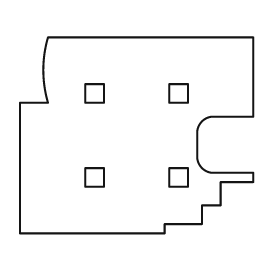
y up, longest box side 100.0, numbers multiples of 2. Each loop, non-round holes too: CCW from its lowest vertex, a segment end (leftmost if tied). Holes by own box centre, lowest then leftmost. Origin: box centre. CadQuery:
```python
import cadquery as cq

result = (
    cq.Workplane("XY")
    .moveTo(-50.0, -42.0)
    .lineTo(12.0, -42.0)
    .lineTo(12.0, -38.0)
    .lineTo(28.0, -38.0)
    .lineTo(28.0, -30.0)
    .lineTo(36.0, -30.0)
    .lineTo(36.0, -20.0)
    .lineTo(50.0, -20.0)
    .lineTo(50.0, -16.0)
    .lineTo(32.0, -16.0)
    .threePointArc((28.0, -14.0), (26.0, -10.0))
    .lineTo(26.0, 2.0)
    .threePointArc((28.0, 6.0), (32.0, 8.0))
    .lineTo(50.0, 8.0)
    .lineTo(50.0, 42.0)
    .lineTo(-38.0, 42.0)
    .threePointArc((-40.0, 28.0), (-38.0, 14.0))
    .lineTo(-50.0, 14.0)
    .close()
    .moveTo(-22.0, -22.0)
    .lineTo(-14.0, -22.0)
    .lineTo(-14.0, -14.0)
    .lineTo(-22.0, -14.0)
    .close()
    .moveTo(14.0, -22.0)
    .lineTo(22.0, -22.0)
    .lineTo(22.0, -14.0)
    .lineTo(14.0, -14.0)
    .close()
    .moveTo(-22.0, 14.0)
    .lineTo(-14.0, 14.0)
    .lineTo(-14.0, 22.0)
    .lineTo(-22.0, 22.0)
    .close()
    .moveTo(14.0, 14.0)
    .lineTo(22.0, 14.0)
    .lineTo(22.0, 22.0)
    .lineTo(14.0, 22.0)
    .close()
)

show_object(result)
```